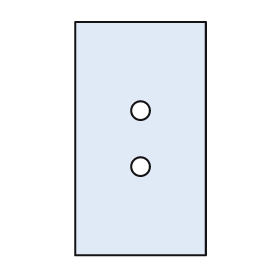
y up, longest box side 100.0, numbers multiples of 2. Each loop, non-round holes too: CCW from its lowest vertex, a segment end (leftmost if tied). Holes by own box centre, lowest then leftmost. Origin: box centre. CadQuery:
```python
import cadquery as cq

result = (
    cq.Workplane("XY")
    .moveTo(-28.0, -50.0)
    .lineTo(28.0, -50.0)
    .lineTo(28.0, 50.0)
    .lineTo(-28.0, 50.0)
    .close()
    .moveTo(0.0, -12.0)
    .circle(4.0)
    .moveTo(0.0, 12.0)
    .circle(4.0)
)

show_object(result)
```